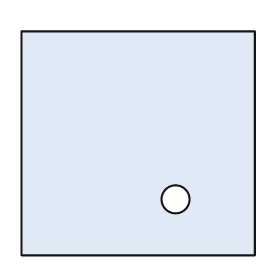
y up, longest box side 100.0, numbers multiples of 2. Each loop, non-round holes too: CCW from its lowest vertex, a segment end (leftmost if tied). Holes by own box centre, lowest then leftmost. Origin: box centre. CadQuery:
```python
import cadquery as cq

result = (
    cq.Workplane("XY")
    .moveTo(-50.0, -48.0)
    .lineTo(50.0, -48.0)
    .lineTo(50.0, 48.0)
    .lineTo(-50.0, 48.0)
    .close()
    .moveTo(16.0, -24.0)
    .circle(6.0)
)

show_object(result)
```